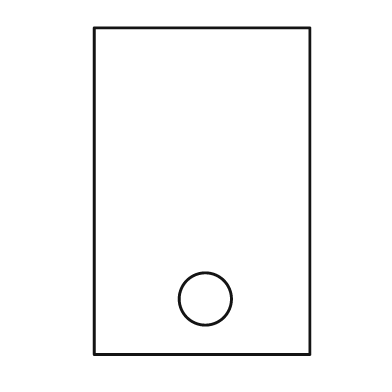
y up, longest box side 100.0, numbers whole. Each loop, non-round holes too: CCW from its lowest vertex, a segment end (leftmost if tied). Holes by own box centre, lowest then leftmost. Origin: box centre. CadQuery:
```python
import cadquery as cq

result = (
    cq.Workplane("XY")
    .moveTo(-33.0, -50.0)
    .lineTo(33.0, -50.0)
    .lineTo(33.0, 50.0)
    .lineTo(-33.0, 50.0)
    .close()
    .moveTo(1.0, -33.0)
    .circle(8.0)
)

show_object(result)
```